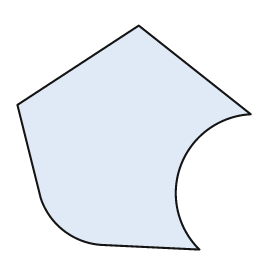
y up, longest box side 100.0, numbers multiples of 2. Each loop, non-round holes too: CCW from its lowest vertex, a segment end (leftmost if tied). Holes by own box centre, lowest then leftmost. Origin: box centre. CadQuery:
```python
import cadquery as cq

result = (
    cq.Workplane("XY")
    .moveTo(28.0, -48.0)
    .threePointArc((20.0, -12.0), (50.0, 10.0))
    .lineTo(2.0, 48.0)
    .lineTo(-50.0, 14.0)
    .lineTo(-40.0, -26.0)
    .threePointArc((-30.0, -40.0), (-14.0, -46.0))
    .close()
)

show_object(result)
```